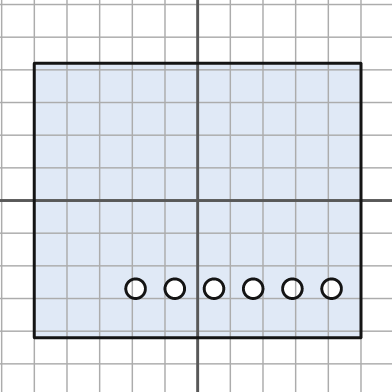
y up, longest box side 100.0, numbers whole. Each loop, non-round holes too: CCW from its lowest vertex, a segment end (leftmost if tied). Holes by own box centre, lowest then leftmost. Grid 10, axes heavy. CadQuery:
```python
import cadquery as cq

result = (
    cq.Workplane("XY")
    .moveTo(-50.0, -42.0)
    .lineTo(50.0, -42.0)
    .lineTo(50.0, 42.0)
    .lineTo(-50.0, 42.0)
    .close()
    .moveTo(-19.0, -27.0)
    .circle(3.0)
    .moveTo(-7.0, -27.0)
    .circle(3.0)
    .moveTo(5.0, -27.0)
    .circle(3.0)
    .moveTo(17.0, -27.0)
    .circle(3.0)
    .moveTo(29.0, -27.0)
    .circle(3.0)
    .moveTo(41.0, -27.0)
    .circle(3.0)
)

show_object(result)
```